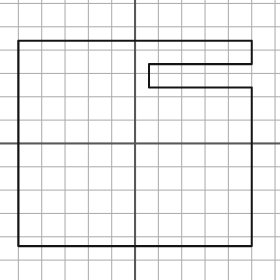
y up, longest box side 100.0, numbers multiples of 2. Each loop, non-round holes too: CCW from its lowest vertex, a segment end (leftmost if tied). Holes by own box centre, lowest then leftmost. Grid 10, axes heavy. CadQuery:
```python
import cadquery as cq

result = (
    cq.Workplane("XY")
    .moveTo(-50.0, -44.0)
    .lineTo(50.0, -44.0)
    .lineTo(50.0, 24.0)
    .lineTo(6.0, 24.0)
    .lineTo(6.0, 34.0)
    .lineTo(50.0, 34.0)
    .lineTo(50.0, 44.0)
    .lineTo(-50.0, 44.0)
    .close()
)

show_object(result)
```